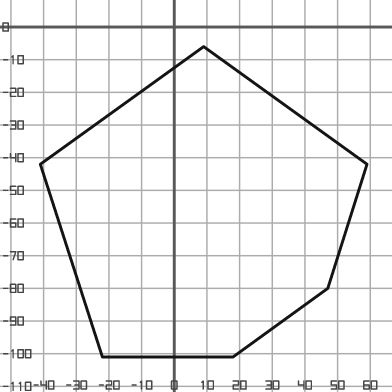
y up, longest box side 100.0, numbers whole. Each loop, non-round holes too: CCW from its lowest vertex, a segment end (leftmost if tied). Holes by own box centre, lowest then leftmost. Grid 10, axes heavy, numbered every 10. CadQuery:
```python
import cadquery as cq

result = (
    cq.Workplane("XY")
    .moveTo(-22.0, -101.0)
    .lineTo(18.0, -101.0)
    .lineTo(47.0, -80.0)
    .lineTo(59.0, -42.0)
    .lineTo(9.0, -6.0)
    .lineTo(-41.0, -42.0)
    .close()
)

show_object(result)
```